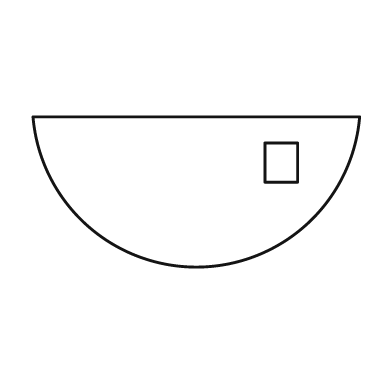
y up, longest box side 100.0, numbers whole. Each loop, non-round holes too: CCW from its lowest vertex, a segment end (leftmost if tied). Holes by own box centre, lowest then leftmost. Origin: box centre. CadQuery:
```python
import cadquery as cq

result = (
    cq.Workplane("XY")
    .moveTo(-50.0, 23.0)
    .threePointArc((0.0, -23.0), (50.0, 23.0))
    .close()
    .moveTo(21.0, 3.0)
    .lineTo(31.0, 3.0)
    .lineTo(31.0, 15.0)
    .lineTo(21.0, 15.0)
    .close()
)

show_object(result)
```